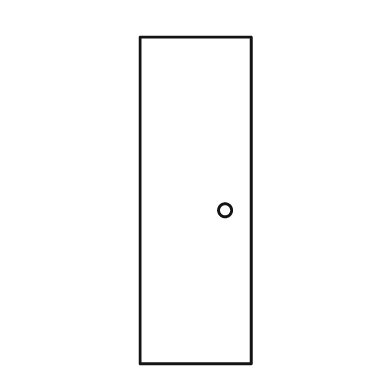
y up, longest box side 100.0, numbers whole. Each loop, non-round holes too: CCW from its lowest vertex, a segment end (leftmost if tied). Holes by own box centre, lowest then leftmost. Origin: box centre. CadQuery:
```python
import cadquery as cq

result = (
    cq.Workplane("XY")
    .moveTo(-17.0, -50.0)
    .lineTo(17.0, -50.0)
    .lineTo(17.0, 50.0)
    .lineTo(-17.0, 50.0)
    .close()
    .moveTo(9.0, -3.0)
    .circle(2.0)
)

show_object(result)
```